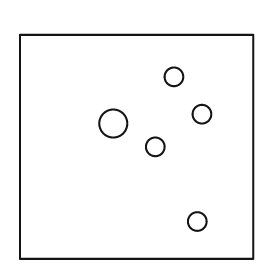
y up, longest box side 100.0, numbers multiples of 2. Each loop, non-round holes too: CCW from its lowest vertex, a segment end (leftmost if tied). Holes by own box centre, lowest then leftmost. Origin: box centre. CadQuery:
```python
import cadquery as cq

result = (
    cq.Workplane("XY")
    .moveTo(-50.0, -48.0)
    .lineTo(50.0, -48.0)
    .lineTo(50.0, 48.0)
    .lineTo(-50.0, 48.0)
    .close()
    .moveTo(26.0, -32.0)
    .circle(4.0)
    .moveTo(8.0, 0.0)
    .circle(4.0)
    .moveTo(-10.0, 10.0)
    .circle(6.0)
    .moveTo(28.0, 14.0)
    .circle(4.0)
    .moveTo(16.0, 30.0)
    .circle(4.0)
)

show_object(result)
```